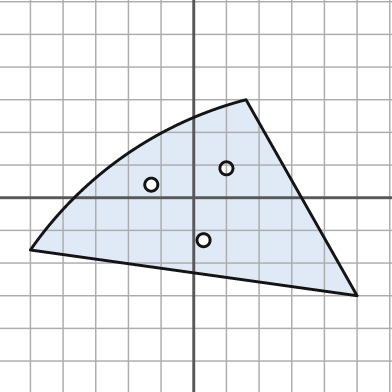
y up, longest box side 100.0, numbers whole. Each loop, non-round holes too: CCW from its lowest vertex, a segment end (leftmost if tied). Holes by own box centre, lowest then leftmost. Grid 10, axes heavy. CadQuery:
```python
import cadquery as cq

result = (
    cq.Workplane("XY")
    .moveTo(50.0, -30.0)
    .lineTo(16.0, 30.0)
    .threePointArc((-21.0, 13.0), (-50.0, -16.0))
    .close()
    .moveTo(3.0, -13.0)
    .circle(2.0)
    .moveTo(-13.0, 4.0)
    .circle(2.0)
    .moveTo(10.0, 9.0)
    .circle(2.0)
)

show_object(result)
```